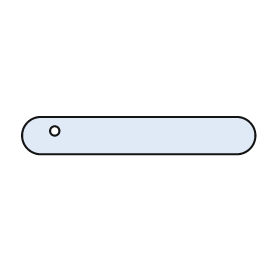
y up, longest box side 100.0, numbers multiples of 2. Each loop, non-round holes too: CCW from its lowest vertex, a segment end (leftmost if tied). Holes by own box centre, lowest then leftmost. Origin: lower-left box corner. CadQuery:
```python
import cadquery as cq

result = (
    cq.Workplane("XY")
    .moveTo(8.0, 0.0)
    .lineTo(92.0, 0.0)
    .threePointArc((100.0, 8.0), (92.0, 16.0))
    .lineTo(8.0, 16.0)
    .threePointArc((0.0, 8.0), (8.0, 0.0))
    .close()
    .moveTo(14.0, 10.0)
    .circle(2.0)
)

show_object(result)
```